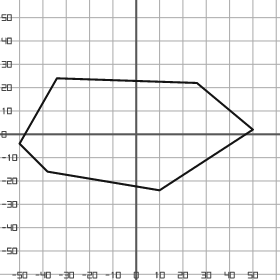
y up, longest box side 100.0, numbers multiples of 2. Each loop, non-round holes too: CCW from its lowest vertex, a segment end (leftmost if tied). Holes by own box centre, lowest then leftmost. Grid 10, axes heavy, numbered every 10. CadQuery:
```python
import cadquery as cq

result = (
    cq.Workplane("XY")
    .moveTo(10.0, -24.0)
    .lineTo(50.0, 2.0)
    .lineTo(26.0, 22.0)
    .lineTo(-34.0, 24.0)
    .lineTo(-50.0, -4.0)
    .lineTo(-38.0, -16.0)
    .close()
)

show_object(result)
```